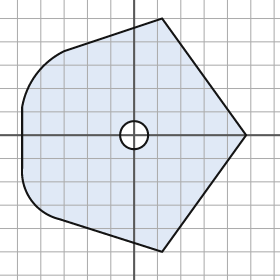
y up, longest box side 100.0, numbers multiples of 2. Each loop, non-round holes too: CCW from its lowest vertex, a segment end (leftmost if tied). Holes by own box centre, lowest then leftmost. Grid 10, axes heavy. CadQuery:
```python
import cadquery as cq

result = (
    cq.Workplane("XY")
    .moveTo(12.0, -50.0)
    .lineTo(48.0, 0.0)
    .lineTo(12.0, 50.0)
    .lineTo(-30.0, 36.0)
    .threePointArc((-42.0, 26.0), (-48.0, 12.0))
    .lineTo(-48.0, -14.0)
    .threePointArc((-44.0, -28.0), (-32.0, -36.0))
    .close()
    .moveTo(0.0, 0.0)
    .circle(6.0)
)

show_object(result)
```